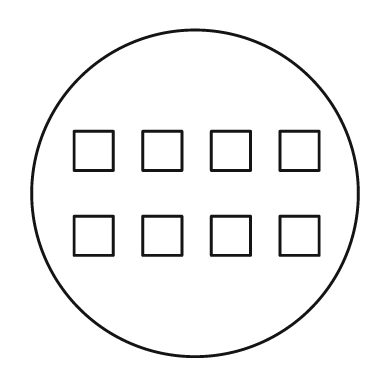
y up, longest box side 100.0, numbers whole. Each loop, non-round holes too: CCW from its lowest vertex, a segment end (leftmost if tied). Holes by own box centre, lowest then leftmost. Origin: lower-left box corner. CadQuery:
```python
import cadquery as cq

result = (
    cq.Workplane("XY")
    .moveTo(50.0, 50.0)
    .circle(50.0)
    .moveTo(13.0, 31.0)
    .lineTo(25.0, 31.0)
    .lineTo(25.0, 43.0)
    .lineTo(13.0, 43.0)
    .close()
    .moveTo(34.0, 31.0)
    .lineTo(46.0, 31.0)
    .lineTo(46.0, 43.0)
    .lineTo(34.0, 43.0)
    .close()
    .moveTo(55.0, 31.0)
    .lineTo(67.0, 31.0)
    .lineTo(67.0, 43.0)
    .lineTo(55.0, 43.0)
    .close()
    .moveTo(76.0, 31.0)
    .lineTo(88.0, 31.0)
    .lineTo(88.0, 43.0)
    .lineTo(76.0, 43.0)
    .close()
    .moveTo(13.0, 57.0)
    .lineTo(25.0, 57.0)
    .lineTo(25.0, 69.0)
    .lineTo(13.0, 69.0)
    .close()
    .moveTo(34.0, 57.0)
    .lineTo(46.0, 57.0)
    .lineTo(46.0, 69.0)
    .lineTo(34.0, 69.0)
    .close()
    .moveTo(55.0, 57.0)
    .lineTo(67.0, 57.0)
    .lineTo(67.0, 69.0)
    .lineTo(55.0, 69.0)
    .close()
    .moveTo(76.0, 57.0)
    .lineTo(88.0, 57.0)
    .lineTo(88.0, 69.0)
    .lineTo(76.0, 69.0)
    .close()
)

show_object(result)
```